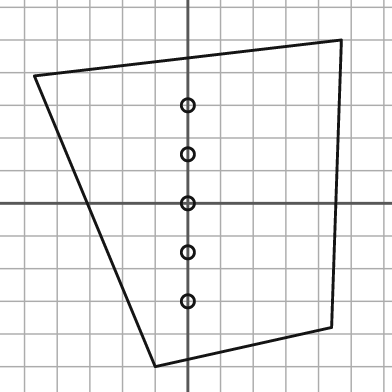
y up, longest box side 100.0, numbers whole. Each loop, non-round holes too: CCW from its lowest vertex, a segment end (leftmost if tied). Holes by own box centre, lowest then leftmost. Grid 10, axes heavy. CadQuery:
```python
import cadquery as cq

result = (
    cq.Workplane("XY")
    .moveTo(-10.0, -50.0)
    .lineTo(44.0, -38.0)
    .lineTo(47.0, 50.0)
    .lineTo(-47.0, 39.0)
    .close()
    .moveTo(0.0, -30.0)
    .circle(2.0)
    .moveTo(0.0, -15.0)
    .circle(2.0)
    .moveTo(0.0, 0.0)
    .circle(2.0)
    .moveTo(0.0, 15.0)
    .circle(2.0)
    .moveTo(0.0, 30.0)
    .circle(2.0)
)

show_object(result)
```